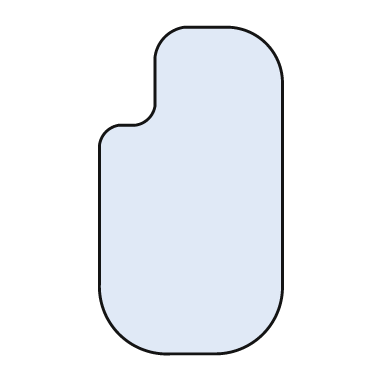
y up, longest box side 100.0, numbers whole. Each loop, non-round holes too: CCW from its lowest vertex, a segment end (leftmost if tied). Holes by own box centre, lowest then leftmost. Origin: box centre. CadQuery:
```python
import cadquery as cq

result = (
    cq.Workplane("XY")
    .moveTo(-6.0, -50.0)
    .lineTo(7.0, -50.0)
    .threePointArc((22.0, -44.0), (28.0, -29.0))
    .lineTo(28.0, 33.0)
    .threePointArc((23.0, 45.0), (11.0, 50.0))
    .lineTo(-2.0, 50.0)
    .threePointArc((-8.0, 47.0), (-11.0, 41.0))
    .lineTo(-11.0, 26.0)
    .threePointArc((-13.0, 22.0), (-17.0, 20.0))
    .lineTo(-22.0, 20.0)
    .threePointArc((-26.0, 18.0), (-28.0, 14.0))
    .lineTo(-28.0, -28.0)
    .threePointArc((-22.0, -44.0), (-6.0, -50.0))
    .close()
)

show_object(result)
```